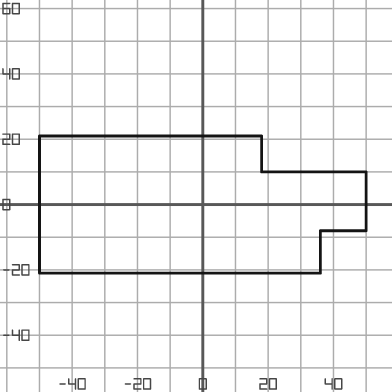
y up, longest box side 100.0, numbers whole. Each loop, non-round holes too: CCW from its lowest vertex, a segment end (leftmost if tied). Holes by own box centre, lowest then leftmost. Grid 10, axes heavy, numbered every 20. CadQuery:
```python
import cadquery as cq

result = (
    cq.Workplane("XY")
    .moveTo(-50.0, -21.0)
    .lineTo(36.0, -21.0)
    .lineTo(36.0, -8.0)
    .lineTo(50.0, -8.0)
    .lineTo(50.0, 10.0)
    .lineTo(18.0, 10.0)
    .lineTo(18.0, 21.0)
    .lineTo(-50.0, 21.0)
    .close()
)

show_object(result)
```